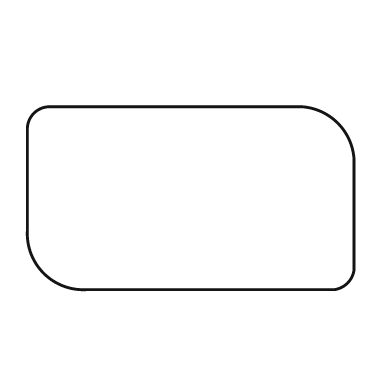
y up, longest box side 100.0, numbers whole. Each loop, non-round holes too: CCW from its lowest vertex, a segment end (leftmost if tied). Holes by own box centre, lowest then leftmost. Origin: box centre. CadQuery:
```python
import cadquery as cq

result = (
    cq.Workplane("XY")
    .moveTo(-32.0, -28.0)
    .lineTo(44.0, -28.0)
    .threePointArc((48.0, -26.0), (50.0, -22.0))
    .lineTo(50.0, 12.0)
    .threePointArc((45.0, 23.0), (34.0, 28.0))
    .lineTo(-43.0, 28.0)
    .threePointArc((-48.0, 26.0), (-50.0, 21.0))
    .lineTo(-50.0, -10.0)
    .threePointArc((-45.0, -23.0), (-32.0, -28.0))
    .close()
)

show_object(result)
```